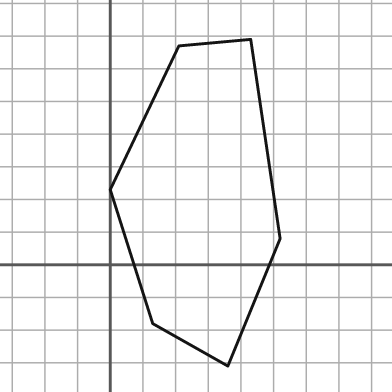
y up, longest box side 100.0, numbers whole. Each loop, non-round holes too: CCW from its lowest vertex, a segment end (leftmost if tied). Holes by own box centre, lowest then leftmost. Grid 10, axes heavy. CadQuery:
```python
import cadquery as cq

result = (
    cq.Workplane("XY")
    .moveTo(36.0, -31.0)
    .lineTo(52.0, 8.0)
    .lineTo(43.0, 69.0)
    .lineTo(21.0, 67.0)
    .lineTo(0.0, 23.0)
    .lineTo(13.0, -18.0)
    .close()
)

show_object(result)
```